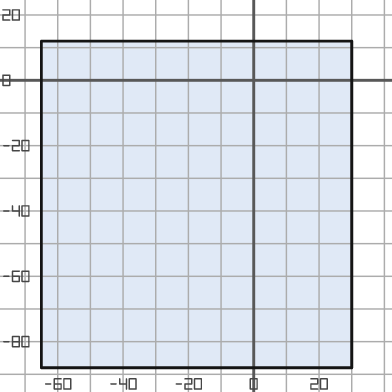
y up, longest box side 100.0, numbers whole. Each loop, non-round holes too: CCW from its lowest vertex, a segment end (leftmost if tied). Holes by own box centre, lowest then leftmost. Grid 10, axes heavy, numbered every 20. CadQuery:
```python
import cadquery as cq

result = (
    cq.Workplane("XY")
    .moveTo(-65.0, -88.0)
    .lineTo(30.0, -88.0)
    .lineTo(30.0, 12.0)
    .lineTo(-65.0, 12.0)
    .close()
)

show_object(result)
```